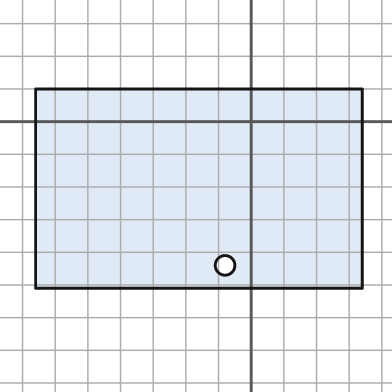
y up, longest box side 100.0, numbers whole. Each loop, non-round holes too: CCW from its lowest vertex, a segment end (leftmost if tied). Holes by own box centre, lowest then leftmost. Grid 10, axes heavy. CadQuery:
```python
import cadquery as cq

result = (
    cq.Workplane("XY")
    .moveTo(-66.0, -51.0)
    .lineTo(34.0, -51.0)
    .lineTo(34.0, 10.0)
    .lineTo(-66.0, 10.0)
    .close()
    .moveTo(-8.0, -44.0)
    .circle(3.0)
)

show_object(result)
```